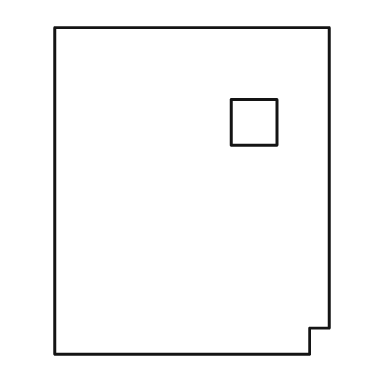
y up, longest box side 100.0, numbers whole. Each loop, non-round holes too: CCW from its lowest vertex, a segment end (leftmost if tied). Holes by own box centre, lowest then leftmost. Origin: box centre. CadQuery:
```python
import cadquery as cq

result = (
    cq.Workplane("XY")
    .moveTo(-42.0, -50.0)
    .lineTo(36.0, -50.0)
    .lineTo(36.0, -42.0)
    .lineTo(42.0, -42.0)
    .lineTo(42.0, 50.0)
    .lineTo(-42.0, 50.0)
    .close()
    .moveTo(12.0, 14.0)
    .lineTo(26.0, 14.0)
    .lineTo(26.0, 28.0)
    .lineTo(12.0, 28.0)
    .close()
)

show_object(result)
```